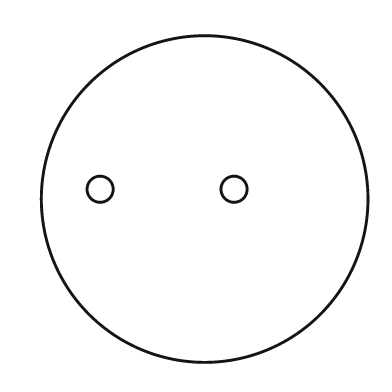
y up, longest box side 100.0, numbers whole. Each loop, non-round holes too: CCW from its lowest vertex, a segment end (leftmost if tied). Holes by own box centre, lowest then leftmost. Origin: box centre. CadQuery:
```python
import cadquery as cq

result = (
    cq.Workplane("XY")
    .moveTo(0.0, 0.0)
    .circle(50.0)
    .moveTo(-32.0, 3.0)
    .circle(4.0)
    .moveTo(9.0, 3.0)
    .circle(4.0)
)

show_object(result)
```